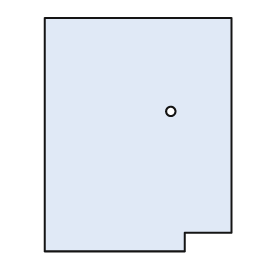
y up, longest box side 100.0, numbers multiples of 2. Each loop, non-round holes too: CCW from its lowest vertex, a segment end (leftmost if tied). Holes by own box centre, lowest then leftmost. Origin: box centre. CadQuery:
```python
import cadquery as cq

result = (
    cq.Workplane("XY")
    .moveTo(-40.0, -50.0)
    .lineTo(20.0, -50.0)
    .lineTo(20.0, -42.0)
    .lineTo(40.0, -42.0)
    .lineTo(40.0, 50.0)
    .lineTo(-40.0, 50.0)
    .close()
    .moveTo(14.0, 10.0)
    .circle(2.0)
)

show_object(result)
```